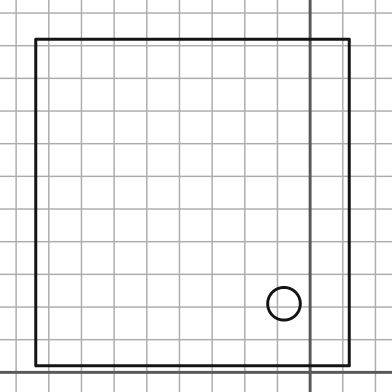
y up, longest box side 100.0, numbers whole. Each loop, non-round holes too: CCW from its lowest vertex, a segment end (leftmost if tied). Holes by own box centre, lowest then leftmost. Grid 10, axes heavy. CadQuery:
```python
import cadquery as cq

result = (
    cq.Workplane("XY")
    .moveTo(-84.0, 2.0)
    .lineTo(12.0, 2.0)
    .lineTo(12.0, 102.0)
    .lineTo(-84.0, 102.0)
    .close()
    .moveTo(-8.0, 21.0)
    .circle(5.0)
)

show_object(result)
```